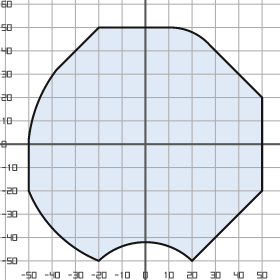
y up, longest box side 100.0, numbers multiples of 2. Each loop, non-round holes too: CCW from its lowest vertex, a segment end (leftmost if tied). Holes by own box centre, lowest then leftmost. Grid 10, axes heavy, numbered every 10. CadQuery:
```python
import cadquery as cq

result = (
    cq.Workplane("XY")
    .moveTo(-20.0, -50.0)
    .threePointArc((0.0, -42.0), (20.0, -50.0))
    .lineTo(50.0, -20.0)
    .lineTo(50.0, 20.0)
    .lineTo(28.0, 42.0)
    .threePointArc((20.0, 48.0), (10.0, 50.0))
    .lineTo(-20.0, 50.0)
    .lineTo(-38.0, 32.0)
    .threePointArc((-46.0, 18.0), (-50.0, 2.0))
    .lineTo(-50.0, -20.0)
    .threePointArc((-38.0, -38.0), (-20.0, -50.0))
    .close()
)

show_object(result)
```